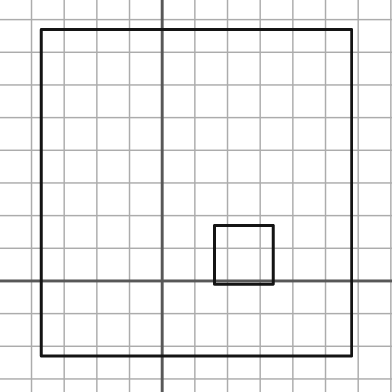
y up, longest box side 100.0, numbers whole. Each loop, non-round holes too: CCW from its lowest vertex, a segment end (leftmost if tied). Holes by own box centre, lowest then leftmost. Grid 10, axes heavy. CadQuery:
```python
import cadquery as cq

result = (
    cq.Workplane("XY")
    .moveTo(-37.0, -23.0)
    .lineTo(58.0, -23.0)
    .lineTo(58.0, 77.0)
    .lineTo(-37.0, 77.0)
    .close()
    .moveTo(16.0, -1.0)
    .lineTo(34.0, -1.0)
    .lineTo(34.0, 17.0)
    .lineTo(16.0, 17.0)
    .close()
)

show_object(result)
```